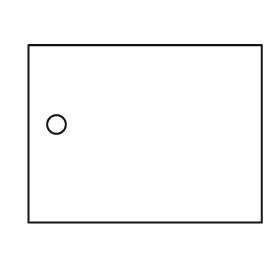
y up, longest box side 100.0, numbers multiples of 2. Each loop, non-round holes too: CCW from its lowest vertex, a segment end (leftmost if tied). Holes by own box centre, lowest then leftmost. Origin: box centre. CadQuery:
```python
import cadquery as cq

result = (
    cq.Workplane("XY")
    .moveTo(-50.0, -38.0)
    .lineTo(50.0, -38.0)
    .lineTo(50.0, 38.0)
    .lineTo(-50.0, 38.0)
    .close()
    .moveTo(-38.0, 4.0)
    .circle(4.0)
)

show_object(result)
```